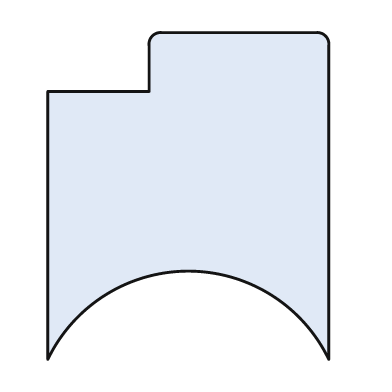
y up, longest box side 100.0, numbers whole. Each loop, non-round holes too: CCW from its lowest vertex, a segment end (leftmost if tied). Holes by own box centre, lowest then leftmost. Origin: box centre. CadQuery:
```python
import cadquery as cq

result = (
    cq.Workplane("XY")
    .moveTo(-43.0, -50.0)
    .threePointArc((0.0, -23.0), (43.0, -50.0))
    .lineTo(43.0, 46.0)
    .threePointArc((42.0, 49.0), (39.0, 50.0))
    .lineTo(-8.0, 50.0)
    .threePointArc((-11.0, 49.0), (-12.0, 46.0))
    .lineTo(-12.0, 32.0)
    .lineTo(-43.0, 32.0)
    .close()
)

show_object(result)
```